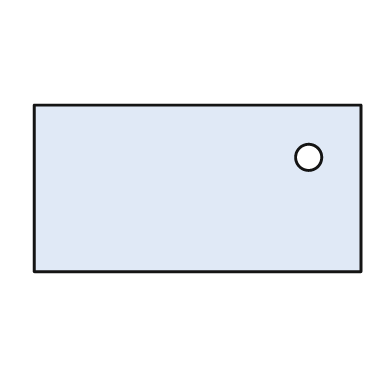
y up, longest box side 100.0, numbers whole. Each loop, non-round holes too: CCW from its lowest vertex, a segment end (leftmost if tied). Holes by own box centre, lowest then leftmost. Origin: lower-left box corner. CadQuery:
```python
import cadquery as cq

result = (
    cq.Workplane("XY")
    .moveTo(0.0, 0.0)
    .lineTo(100.0, 0.0)
    .lineTo(100.0, 51.0)
    .lineTo(0.0, 51.0)
    .close()
    .moveTo(84.0, 35.0)
    .circle(4.0)
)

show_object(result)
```